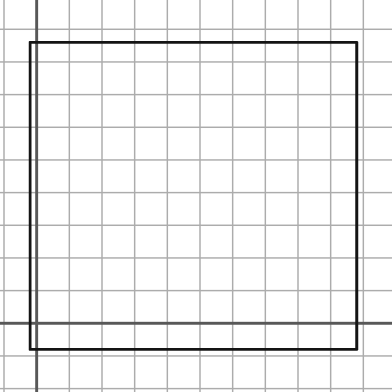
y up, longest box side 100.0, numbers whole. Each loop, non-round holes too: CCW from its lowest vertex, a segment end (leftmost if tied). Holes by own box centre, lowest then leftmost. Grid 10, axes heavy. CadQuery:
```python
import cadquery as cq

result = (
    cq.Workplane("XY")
    .moveTo(-2.0, -8.0)
    .lineTo(98.0, -8.0)
    .lineTo(98.0, 86.0)
    .lineTo(-2.0, 86.0)
    .close()
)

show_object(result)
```